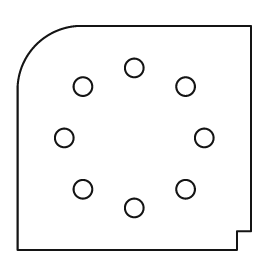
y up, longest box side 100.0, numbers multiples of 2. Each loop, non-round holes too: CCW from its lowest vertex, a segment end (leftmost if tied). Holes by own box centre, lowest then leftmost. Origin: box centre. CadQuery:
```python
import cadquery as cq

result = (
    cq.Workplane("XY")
    .moveTo(-50.0, -48.0)
    .lineTo(44.0, -48.0)
    .lineTo(44.0, -40.0)
    .lineTo(50.0, -40.0)
    .lineTo(50.0, 48.0)
    .lineTo(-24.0, 48.0)
    .threePointArc((-42.0, 40.0), (-50.0, 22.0))
    .close()
    .moveTo(0.0, -30.0)
    .circle(4.0)
    .moveTo(-22.0, -22.0)
    .circle(4.0)
    .moveTo(22.0, -22.0)
    .circle(4.0)
    .moveTo(-30.0, 0.0)
    .circle(4.0)
    .moveTo(30.0, 0.0)
    .circle(4.0)
    .moveTo(-22.0, 22.0)
    .circle(4.0)
    .moveTo(22.0, 22.0)
    .circle(4.0)
    .moveTo(0.0, 30.0)
    .circle(4.0)
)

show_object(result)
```